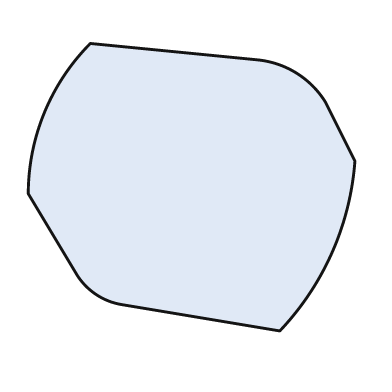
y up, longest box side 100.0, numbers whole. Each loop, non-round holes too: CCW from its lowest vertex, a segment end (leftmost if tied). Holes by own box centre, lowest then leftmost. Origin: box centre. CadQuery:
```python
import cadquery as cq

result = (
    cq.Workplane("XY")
    .moveTo(27.0, -44.0)
    .threePointArc((43.0, -20.0), (50.0, 8.0))
    .lineTo(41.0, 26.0)
    .threePointArc((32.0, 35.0), (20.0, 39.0))
    .lineTo(-31.0, 44.0)
    .threePointArc((-45.0, 23.0), (-50.0, -2.0))
    .lineTo(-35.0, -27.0)
    .threePointArc((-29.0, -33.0), (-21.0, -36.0))
    .close()
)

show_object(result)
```